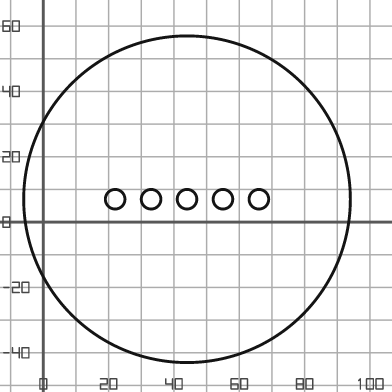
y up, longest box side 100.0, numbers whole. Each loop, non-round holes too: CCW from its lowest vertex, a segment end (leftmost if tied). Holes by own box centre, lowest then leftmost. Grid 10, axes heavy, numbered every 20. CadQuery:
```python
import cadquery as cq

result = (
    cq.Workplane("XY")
    .moveTo(44.0, 7.0)
    .circle(50.0)
    .moveTo(22.0, 7.0)
    .circle(3.0)
    .moveTo(33.0, 7.0)
    .circle(3.0)
    .moveTo(44.0, 7.0)
    .circle(3.0)
    .moveTo(55.0, 7.0)
    .circle(3.0)
    .moveTo(66.0, 7.0)
    .circle(3.0)
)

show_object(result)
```